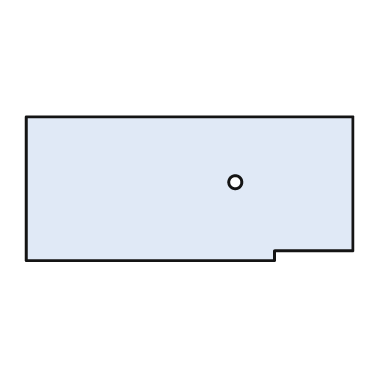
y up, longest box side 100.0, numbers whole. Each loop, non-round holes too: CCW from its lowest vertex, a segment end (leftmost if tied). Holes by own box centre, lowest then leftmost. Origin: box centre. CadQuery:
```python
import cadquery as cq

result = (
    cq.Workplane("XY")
    .moveTo(-50.0, -22.0)
    .lineTo(26.0, -22.0)
    .lineTo(26.0, -19.0)
    .lineTo(50.0, -19.0)
    .lineTo(50.0, 22.0)
    .lineTo(-50.0, 22.0)
    .close()
    .moveTo(14.0, 2.0)
    .circle(2.0)
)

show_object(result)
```